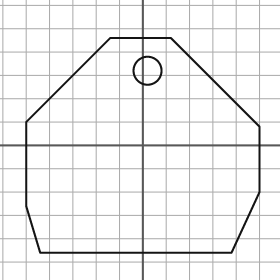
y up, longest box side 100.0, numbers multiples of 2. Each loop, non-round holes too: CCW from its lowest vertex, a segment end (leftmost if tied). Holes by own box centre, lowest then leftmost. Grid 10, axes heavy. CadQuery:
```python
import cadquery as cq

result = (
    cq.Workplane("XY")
    .moveTo(-44.0, -46.0)
    .lineTo(38.0, -46.0)
    .lineTo(50.0, -20.0)
    .lineTo(50.0, 8.0)
    .lineTo(12.0, 46.0)
    .lineTo(-14.0, 46.0)
    .lineTo(-50.0, 10.0)
    .lineTo(-50.0, -26.0)
    .close()
    .moveTo(2.0, 32.0)
    .circle(6.0)
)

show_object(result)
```